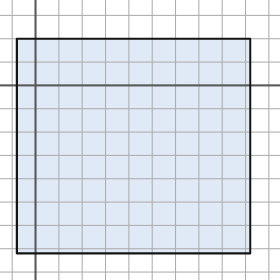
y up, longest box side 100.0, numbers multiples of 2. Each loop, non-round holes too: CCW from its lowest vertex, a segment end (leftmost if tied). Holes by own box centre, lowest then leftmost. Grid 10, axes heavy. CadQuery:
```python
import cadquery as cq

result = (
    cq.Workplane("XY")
    .moveTo(-8.0, -72.0)
    .lineTo(92.0, -72.0)
    .lineTo(92.0, 20.0)
    .lineTo(-8.0, 20.0)
    .close()
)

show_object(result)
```